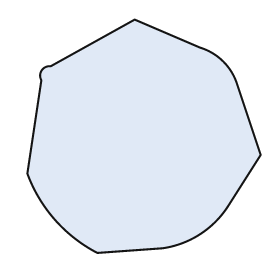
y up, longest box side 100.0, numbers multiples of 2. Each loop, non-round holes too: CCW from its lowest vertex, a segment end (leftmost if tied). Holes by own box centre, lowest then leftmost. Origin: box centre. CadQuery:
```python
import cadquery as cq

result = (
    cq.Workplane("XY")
    .moveTo(-20.0, -50.0)
    .lineTo(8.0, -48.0)
    .threePointArc((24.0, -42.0), (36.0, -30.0))
    .lineTo(50.0, -8.0)
    .lineTo(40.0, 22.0)
    .threePointArc((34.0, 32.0), (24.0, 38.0))
    .lineTo(-4.0, 50.0)
    .lineTo(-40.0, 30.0)
    .threePointArc((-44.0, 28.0), (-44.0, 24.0))
    .lineTo(-50.0, -16.0)
    .threePointArc((-38.0, -36.0), (-20.0, -50.0))
    .close()
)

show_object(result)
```